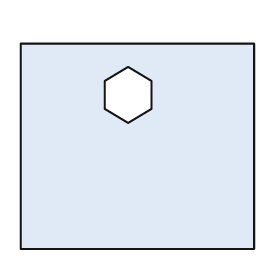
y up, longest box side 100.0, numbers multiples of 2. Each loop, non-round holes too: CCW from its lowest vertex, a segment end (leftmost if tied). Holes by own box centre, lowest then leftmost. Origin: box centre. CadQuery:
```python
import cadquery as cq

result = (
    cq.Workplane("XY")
    .moveTo(-50.0, -44.0)
    .lineTo(50.0, -44.0)
    .lineTo(50.0, 44.0)
    .lineTo(-50.0, 44.0)
    .close()
    .moveTo(-4.0, 10.0)
    .lineTo(6.0, 16.0)
    .lineTo(6.0, 28.0)
    .lineTo(-4.0, 34.0)
    .lineTo(-14.0, 28.0)
    .lineTo(-14.0, 16.0)
    .close()
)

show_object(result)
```